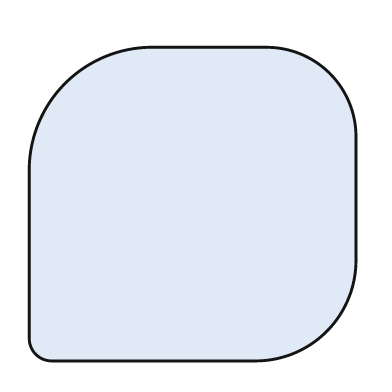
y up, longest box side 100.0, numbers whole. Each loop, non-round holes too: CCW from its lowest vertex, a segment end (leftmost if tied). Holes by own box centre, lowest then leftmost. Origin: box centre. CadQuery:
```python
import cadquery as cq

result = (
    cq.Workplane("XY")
    .moveTo(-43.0, -48.0)
    .lineTo(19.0, -48.0)
    .threePointArc((41.0, -39.0), (50.0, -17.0))
    .lineTo(50.0, 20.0)
    .threePointArc((42.0, 40.0), (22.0, 48.0))
    .lineTo(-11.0, 48.0)
    .threePointArc((-39.0, 37.0), (-50.0, 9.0))
    .lineTo(-50.0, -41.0)
    .threePointArc((-48.0, -46.0), (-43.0, -48.0))
    .close()
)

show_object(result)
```